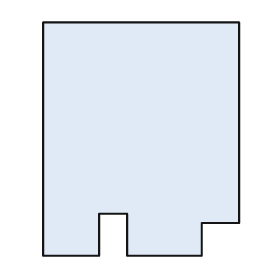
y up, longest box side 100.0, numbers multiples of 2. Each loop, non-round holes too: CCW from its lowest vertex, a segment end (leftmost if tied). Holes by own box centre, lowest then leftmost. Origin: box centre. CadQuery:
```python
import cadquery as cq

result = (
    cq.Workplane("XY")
    .moveTo(-42.0, -50.0)
    .lineTo(-18.0, -50.0)
    .lineTo(-18.0, -32.0)
    .lineTo(-6.0, -32.0)
    .lineTo(-6.0, -50.0)
    .lineTo(26.0, -50.0)
    .lineTo(26.0, -36.0)
    .lineTo(42.0, -36.0)
    .lineTo(42.0, 50.0)
    .lineTo(-42.0, 50.0)
    .close()
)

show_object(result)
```